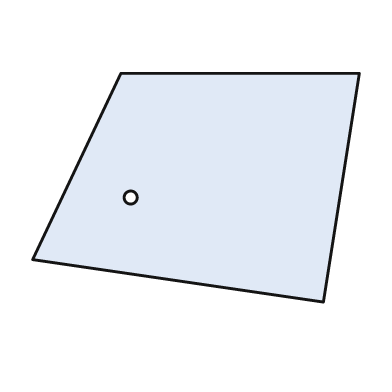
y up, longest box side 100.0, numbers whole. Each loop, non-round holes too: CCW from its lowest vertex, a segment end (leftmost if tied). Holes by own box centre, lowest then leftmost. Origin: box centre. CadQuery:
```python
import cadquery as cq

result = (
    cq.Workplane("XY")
    .moveTo(39.0, -35.0)
    .lineTo(50.0, 35.0)
    .lineTo(-23.0, 35.0)
    .lineTo(-50.0, -22.0)
    .close()
    .moveTo(-20.0, -3.0)
    .circle(2.0)
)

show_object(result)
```